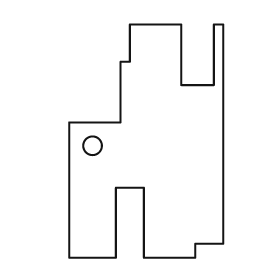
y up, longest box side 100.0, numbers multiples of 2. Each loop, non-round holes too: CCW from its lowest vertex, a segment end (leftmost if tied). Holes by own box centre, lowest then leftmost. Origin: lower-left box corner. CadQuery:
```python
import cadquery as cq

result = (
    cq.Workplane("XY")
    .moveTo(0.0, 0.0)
    .lineTo(20.0, 0.0)
    .lineTo(20.0, 30.0)
    .lineTo(32.0, 30.0)
    .lineTo(32.0, 0.0)
    .lineTo(54.0, 0.0)
    .lineTo(54.0, 6.0)
    .lineTo(66.0, 6.0)
    .lineTo(66.0, 100.0)
    .lineTo(62.0, 100.0)
    .lineTo(62.0, 74.0)
    .lineTo(48.0, 74.0)
    .lineTo(48.0, 100.0)
    .lineTo(26.0, 100.0)
    .lineTo(26.0, 84.0)
    .lineTo(22.0, 84.0)
    .lineTo(22.0, 58.0)
    .lineTo(0.0, 58.0)
    .close()
    .moveTo(10.0, 48.0)
    .circle(4.0)
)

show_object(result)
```